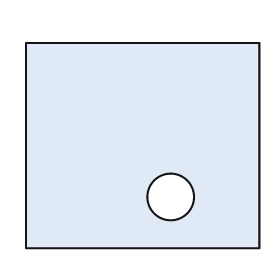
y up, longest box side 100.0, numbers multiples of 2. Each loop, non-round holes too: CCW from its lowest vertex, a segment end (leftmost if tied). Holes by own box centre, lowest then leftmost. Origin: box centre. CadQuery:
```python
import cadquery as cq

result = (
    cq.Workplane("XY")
    .moveTo(-50.0, -44.0)
    .lineTo(50.0, -44.0)
    .lineTo(50.0, 44.0)
    .lineTo(-50.0, 44.0)
    .close()
    .moveTo(12.0, -22.0)
    .circle(10.0)
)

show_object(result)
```